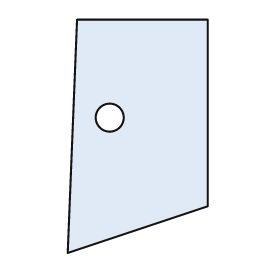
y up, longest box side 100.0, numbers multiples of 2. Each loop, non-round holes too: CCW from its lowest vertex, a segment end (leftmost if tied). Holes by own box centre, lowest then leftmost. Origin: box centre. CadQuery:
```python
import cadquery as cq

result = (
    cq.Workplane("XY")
    .moveTo(-30.0, -50.0)
    .lineTo(30.0, -30.0)
    .lineTo(30.0, 50.0)
    .lineTo(-26.0, 50.0)
    .close()
    .moveTo(-12.0, 8.0)
    .circle(6.0)
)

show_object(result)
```